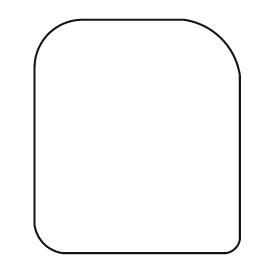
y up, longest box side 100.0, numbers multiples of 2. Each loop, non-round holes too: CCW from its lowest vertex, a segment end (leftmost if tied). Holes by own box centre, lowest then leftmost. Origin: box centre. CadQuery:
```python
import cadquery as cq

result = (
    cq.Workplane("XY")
    .moveTo(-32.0, -50.0)
    .lineTo(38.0, -50.0)
    .threePointArc((42.0, -48.0), (44.0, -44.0))
    .lineTo(44.0, 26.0)
    .threePointArc((36.0, 42.0), (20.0, 50.0))
    .lineTo(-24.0, 50.0)
    .threePointArc((-38.0, 44.0), (-44.0, 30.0))
    .lineTo(-44.0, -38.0)
    .threePointArc((-40.0, -46.0), (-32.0, -50.0))
    .close()
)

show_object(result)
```